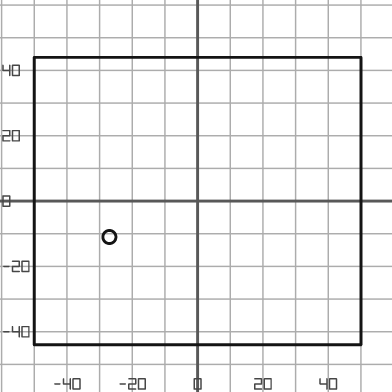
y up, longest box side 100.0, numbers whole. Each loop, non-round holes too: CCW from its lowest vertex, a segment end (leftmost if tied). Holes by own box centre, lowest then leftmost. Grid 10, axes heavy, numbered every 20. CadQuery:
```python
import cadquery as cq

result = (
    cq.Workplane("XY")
    .moveTo(-50.0, -44.0)
    .lineTo(50.0, -44.0)
    .lineTo(50.0, 44.0)
    .lineTo(-50.0, 44.0)
    .close()
    .moveTo(-27.0, -11.0)
    .circle(2.0)
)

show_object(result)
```